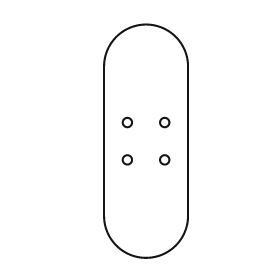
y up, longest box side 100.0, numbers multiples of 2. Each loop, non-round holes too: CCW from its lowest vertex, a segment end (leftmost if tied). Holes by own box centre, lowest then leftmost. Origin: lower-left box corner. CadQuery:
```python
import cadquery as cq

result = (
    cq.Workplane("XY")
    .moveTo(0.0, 18.0)
    .threePointArc((18.0, 0.0), (36.0, 18.0))
    .lineTo(36.0, 82.0)
    .threePointArc((18.0, 100.0), (0.0, 82.0))
    .close()
    .moveTo(10.0, 42.0)
    .circle(2.0)
    .moveTo(26.0, 42.0)
    .circle(2.0)
    .moveTo(10.0, 58.0)
    .circle(2.0)
    .moveTo(26.0, 58.0)
    .circle(2.0)
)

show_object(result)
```